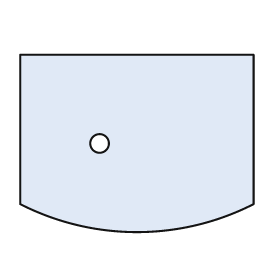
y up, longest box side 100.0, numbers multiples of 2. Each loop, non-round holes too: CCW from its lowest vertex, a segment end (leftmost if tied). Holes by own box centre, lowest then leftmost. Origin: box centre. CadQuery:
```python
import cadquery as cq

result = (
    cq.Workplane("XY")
    .moveTo(-50.0, -26.0)
    .threePointArc((0.0, -38.0), (50.0, -26.0))
    .lineTo(50.0, 38.0)
    .lineTo(-50.0, 38.0)
    .close()
    .moveTo(-16.0, 0.0)
    .circle(4.0)
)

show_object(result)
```